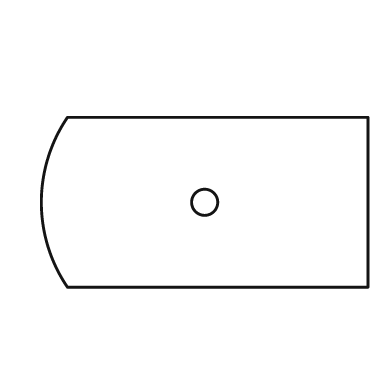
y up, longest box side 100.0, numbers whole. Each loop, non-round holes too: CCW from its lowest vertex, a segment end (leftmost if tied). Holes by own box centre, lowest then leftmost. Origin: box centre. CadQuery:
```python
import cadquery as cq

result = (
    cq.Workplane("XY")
    .moveTo(-42.0, -26.0)
    .lineTo(50.0, -26.0)
    .lineTo(50.0, 26.0)
    .lineTo(-42.0, 26.0)
    .threePointArc((-50.0, 0.0), (-42.0, -26.0))
    .close()
    .moveTo(0.0, 0.0)
    .circle(4.0)
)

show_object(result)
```